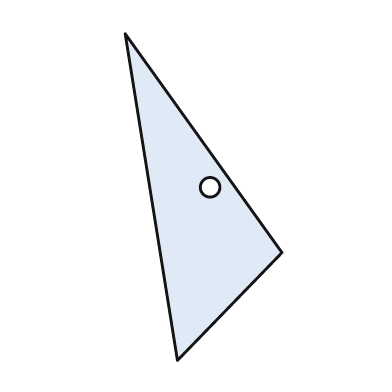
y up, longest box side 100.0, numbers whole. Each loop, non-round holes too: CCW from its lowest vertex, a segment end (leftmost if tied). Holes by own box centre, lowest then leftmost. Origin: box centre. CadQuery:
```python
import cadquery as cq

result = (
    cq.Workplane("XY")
    .moveTo(-8.0, -50.0)
    .lineTo(24.0, -17.0)
    .lineTo(-24.0, 50.0)
    .close()
    .moveTo(2.0, 3.0)
    .circle(3.0)
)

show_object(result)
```